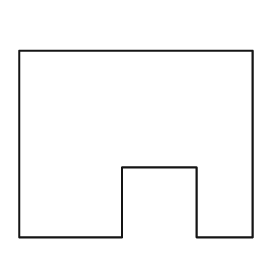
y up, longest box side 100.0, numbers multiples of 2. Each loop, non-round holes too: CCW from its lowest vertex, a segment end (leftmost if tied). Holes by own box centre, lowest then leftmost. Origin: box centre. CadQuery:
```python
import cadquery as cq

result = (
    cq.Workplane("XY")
    .moveTo(-50.0, -40.0)
    .lineTo(-6.0, -40.0)
    .lineTo(-6.0, -10.0)
    .lineTo(26.0, -10.0)
    .lineTo(26.0, -40.0)
    .lineTo(50.0, -40.0)
    .lineTo(50.0, 40.0)
    .lineTo(-50.0, 40.0)
    .close()
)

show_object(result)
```